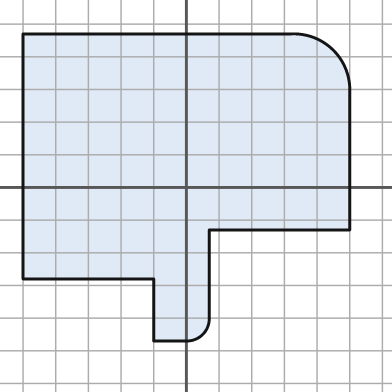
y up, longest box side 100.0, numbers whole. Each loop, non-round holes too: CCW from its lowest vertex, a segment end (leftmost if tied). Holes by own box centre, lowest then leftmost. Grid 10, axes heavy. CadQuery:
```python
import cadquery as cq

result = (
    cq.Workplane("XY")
    .moveTo(-10.0, -47.0)
    .lineTo(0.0, -47.0)
    .threePointArc((5.0, -45.0), (7.0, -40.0))
    .lineTo(7.0, -13.0)
    .lineTo(50.0, -13.0)
    .lineTo(50.0, 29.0)
    .threePointArc((45.0, 42.0), (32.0, 47.0))
    .lineTo(-50.0, 47.0)
    .lineTo(-50.0, -28.0)
    .lineTo(-10.0, -28.0)
    .close()
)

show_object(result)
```